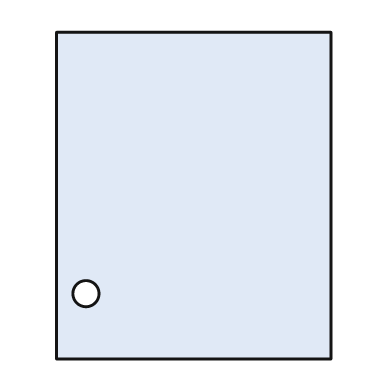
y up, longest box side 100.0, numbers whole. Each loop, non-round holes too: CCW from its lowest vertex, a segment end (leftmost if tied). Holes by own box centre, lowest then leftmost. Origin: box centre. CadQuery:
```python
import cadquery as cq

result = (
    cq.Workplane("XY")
    .moveTo(-42.0, -50.0)
    .lineTo(42.0, -50.0)
    .lineTo(42.0, 50.0)
    .lineTo(-42.0, 50.0)
    .close()
    .moveTo(-33.0, -30.0)
    .circle(4.0)
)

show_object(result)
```